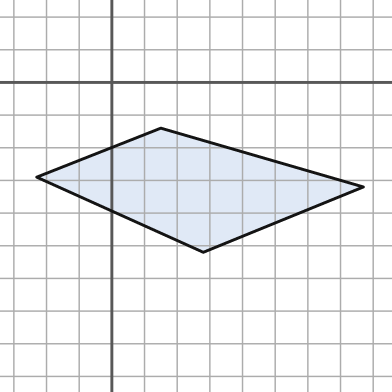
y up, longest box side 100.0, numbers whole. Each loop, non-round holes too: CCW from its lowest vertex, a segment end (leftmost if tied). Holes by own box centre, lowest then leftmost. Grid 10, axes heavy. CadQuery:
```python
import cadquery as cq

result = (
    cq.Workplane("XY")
    .moveTo(28.0, -52.0)
    .lineTo(77.0, -32.0)
    .lineTo(15.0, -14.0)
    .lineTo(-23.0, -29.0)
    .close()
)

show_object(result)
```